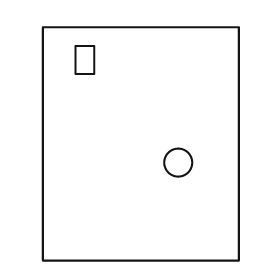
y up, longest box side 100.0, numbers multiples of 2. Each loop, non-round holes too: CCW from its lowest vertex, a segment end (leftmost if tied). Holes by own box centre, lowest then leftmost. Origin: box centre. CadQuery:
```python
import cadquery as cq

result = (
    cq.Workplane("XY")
    .moveTo(-42.0, -50.0)
    .lineTo(42.0, -50.0)
    .lineTo(42.0, 50.0)
    .lineTo(-42.0, 50.0)
    .close()
    .moveTo(16.0, -8.0)
    .circle(6.0)
    .moveTo(-28.0, 30.0)
    .lineTo(-20.0, 30.0)
    .lineTo(-20.0, 42.0)
    .lineTo(-28.0, 42.0)
    .close()
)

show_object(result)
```